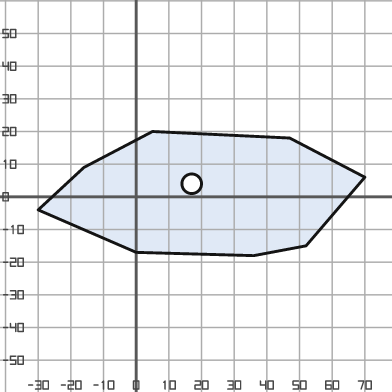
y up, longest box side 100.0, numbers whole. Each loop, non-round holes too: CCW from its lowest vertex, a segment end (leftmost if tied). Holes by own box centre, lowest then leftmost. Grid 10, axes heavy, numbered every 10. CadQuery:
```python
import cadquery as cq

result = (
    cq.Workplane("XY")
    .moveTo(36.0, -18.0)
    .lineTo(52.0, -15.0)
    .lineTo(70.0, 6.0)
    .lineTo(47.0, 18.0)
    .lineTo(5.0, 20.0)
    .lineTo(-16.0, 9.0)
    .lineTo(-30.0, -4.0)
    .lineTo(0.0, -17.0)
    .close()
    .moveTo(17.0, 4.0)
    .circle(3.0)
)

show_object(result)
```